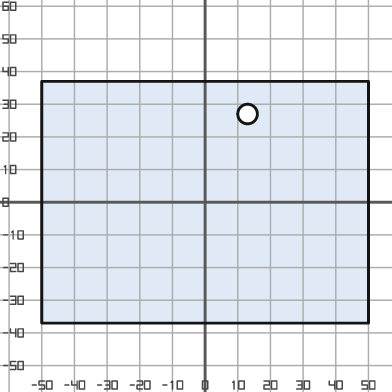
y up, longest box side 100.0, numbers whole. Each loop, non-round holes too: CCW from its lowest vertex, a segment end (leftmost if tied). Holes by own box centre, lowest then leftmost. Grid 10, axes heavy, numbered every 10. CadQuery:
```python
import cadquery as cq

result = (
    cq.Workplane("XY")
    .moveTo(-50.0, -37.0)
    .lineTo(50.0, -37.0)
    .lineTo(50.0, 37.0)
    .lineTo(-50.0, 37.0)
    .close()
    .moveTo(13.0, 27.0)
    .circle(3.0)
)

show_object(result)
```